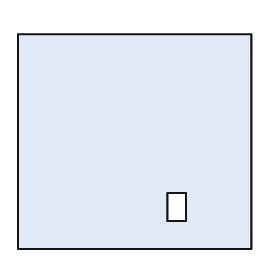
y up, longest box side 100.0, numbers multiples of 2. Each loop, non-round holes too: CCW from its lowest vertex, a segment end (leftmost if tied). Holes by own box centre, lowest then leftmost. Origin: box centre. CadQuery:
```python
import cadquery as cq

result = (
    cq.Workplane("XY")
    .moveTo(-50.0, -46.0)
    .lineTo(50.0, -46.0)
    .lineTo(50.0, 46.0)
    .lineTo(-50.0, 46.0)
    .close()
    .moveTo(14.0, -34.0)
    .lineTo(22.0, -34.0)
    .lineTo(22.0, -22.0)
    .lineTo(14.0, -22.0)
    .close()
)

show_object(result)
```